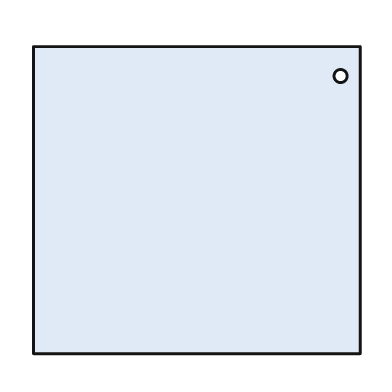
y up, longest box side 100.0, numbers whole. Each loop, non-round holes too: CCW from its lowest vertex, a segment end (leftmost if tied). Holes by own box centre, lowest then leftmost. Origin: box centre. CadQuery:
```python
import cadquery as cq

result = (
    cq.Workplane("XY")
    .moveTo(-50.0, -47.0)
    .lineTo(50.0, -47.0)
    .lineTo(50.0, 47.0)
    .lineTo(-50.0, 47.0)
    .close()
    .moveTo(44.0, 38.0)
    .circle(2.0)
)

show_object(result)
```